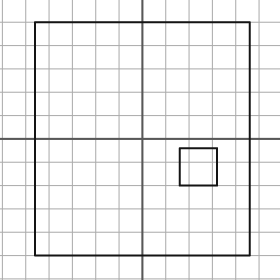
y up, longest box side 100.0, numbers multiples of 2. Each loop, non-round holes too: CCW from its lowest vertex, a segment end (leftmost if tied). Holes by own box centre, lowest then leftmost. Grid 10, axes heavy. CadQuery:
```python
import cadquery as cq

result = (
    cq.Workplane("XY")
    .moveTo(-46.0, -50.0)
    .lineTo(46.0, -50.0)
    .lineTo(46.0, 50.0)
    .lineTo(-46.0, 50.0)
    .close()
    .moveTo(16.0, -20.0)
    .lineTo(32.0, -20.0)
    .lineTo(32.0, -4.0)
    .lineTo(16.0, -4.0)
    .close()
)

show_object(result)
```